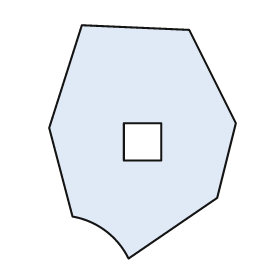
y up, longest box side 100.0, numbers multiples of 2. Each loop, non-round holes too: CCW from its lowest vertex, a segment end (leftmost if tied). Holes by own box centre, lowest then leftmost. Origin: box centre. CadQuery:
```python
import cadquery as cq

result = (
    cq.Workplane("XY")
    .moveTo(-6.0, -50.0)
    .lineTo(32.0, -24.0)
    .lineTo(40.0, 8.0)
    .lineTo(20.0, 48.0)
    .lineTo(-26.0, 50.0)
    .lineTo(-40.0, 6.0)
    .lineTo(-30.0, -32.0)
    .threePointArc((-16.0, -38.0), (-6.0, -50.0))
    .close()
    .moveTo(-8.0, -8.0)
    .lineTo(8.0, -8.0)
    .lineTo(8.0, 8.0)
    .lineTo(-8.0, 8.0)
    .close()
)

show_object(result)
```